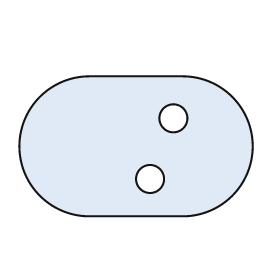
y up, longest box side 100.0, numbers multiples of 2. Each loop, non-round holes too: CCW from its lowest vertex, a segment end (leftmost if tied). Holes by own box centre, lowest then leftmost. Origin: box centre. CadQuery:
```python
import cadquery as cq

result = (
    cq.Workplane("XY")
    .moveTo(-20.0, -30.0)
    .lineTo(20.0, -30.0)
    .threePointArc((50.0, 0.0), (20.0, 30.0))
    .lineTo(-20.0, 30.0)
    .threePointArc((-50.0, 0.0), (-20.0, -30.0))
    .close()
    .moveTo(6.0, -14.0)
    .circle(6.0)
    .moveTo(16.0, 12.0)
    .circle(6.0)
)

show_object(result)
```